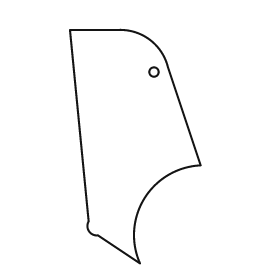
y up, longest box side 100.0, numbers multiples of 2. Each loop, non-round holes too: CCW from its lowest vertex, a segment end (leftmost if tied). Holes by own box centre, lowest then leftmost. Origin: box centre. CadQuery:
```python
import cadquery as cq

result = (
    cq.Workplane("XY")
    .moveTo(2.0, -50.0)
    .threePointArc((4.0, -22.0), (28.0, -8.0))
    .lineTo(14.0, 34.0)
    .threePointArc((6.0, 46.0), (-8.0, 50.0))
    .lineTo(-28.0, 50.0)
    .lineTo(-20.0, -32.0)
    .threePointArc((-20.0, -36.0), (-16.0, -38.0))
    .close()
    .moveTo(8.0, 32.0)
    .circle(2.0)
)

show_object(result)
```